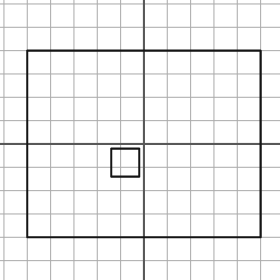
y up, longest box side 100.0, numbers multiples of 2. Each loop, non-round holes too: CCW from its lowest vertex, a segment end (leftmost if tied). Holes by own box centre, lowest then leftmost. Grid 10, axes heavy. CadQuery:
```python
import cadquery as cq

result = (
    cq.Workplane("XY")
    .moveTo(-50.0, -40.0)
    .lineTo(50.0, -40.0)
    .lineTo(50.0, 40.0)
    .lineTo(-50.0, 40.0)
    .close()
    .moveTo(-14.0, -14.0)
    .lineTo(-2.0, -14.0)
    .lineTo(-2.0, -2.0)
    .lineTo(-14.0, -2.0)
    .close()
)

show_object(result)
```